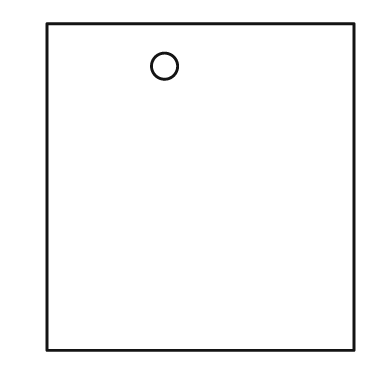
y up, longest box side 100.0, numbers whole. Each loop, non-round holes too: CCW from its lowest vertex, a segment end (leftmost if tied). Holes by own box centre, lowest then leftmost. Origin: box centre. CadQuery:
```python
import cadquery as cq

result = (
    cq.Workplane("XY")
    .moveTo(-47.0, -50.0)
    .lineTo(47.0, -50.0)
    .lineTo(47.0, 50.0)
    .lineTo(-47.0, 50.0)
    .close()
    .moveTo(-11.0, 37.0)
    .circle(4.0)
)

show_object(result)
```